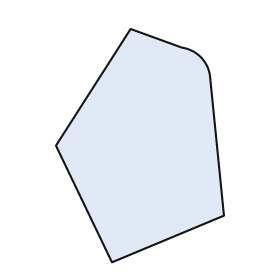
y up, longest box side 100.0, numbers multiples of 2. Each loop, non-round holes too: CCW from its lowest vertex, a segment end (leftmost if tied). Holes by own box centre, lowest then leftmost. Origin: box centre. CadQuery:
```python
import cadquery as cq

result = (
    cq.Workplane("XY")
    .moveTo(-12.0, -50.0)
    .lineTo(36.0, -30.0)
    .lineTo(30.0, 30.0)
    .threePointArc((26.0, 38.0), (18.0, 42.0))
    .lineTo(-4.0, 50.0)
    .lineTo(-36.0, 0.0)
    .close()
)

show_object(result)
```